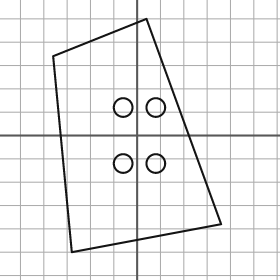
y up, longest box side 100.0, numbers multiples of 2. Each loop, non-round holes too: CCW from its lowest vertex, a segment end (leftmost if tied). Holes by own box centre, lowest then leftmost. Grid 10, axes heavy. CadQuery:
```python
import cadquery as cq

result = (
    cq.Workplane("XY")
    .moveTo(-28.0, -50.0)
    .lineTo(36.0, -38.0)
    .lineTo(4.0, 50.0)
    .lineTo(-36.0, 34.0)
    .close()
    .moveTo(-6.0, -12.0)
    .circle(4.0)
    .moveTo(8.0, -12.0)
    .circle(4.0)
    .moveTo(-6.0, 12.0)
    .circle(4.0)
    .moveTo(8.0, 12.0)
    .circle(4.0)
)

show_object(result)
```